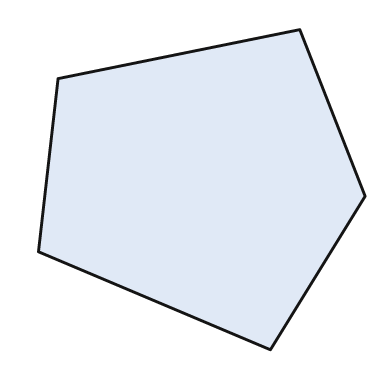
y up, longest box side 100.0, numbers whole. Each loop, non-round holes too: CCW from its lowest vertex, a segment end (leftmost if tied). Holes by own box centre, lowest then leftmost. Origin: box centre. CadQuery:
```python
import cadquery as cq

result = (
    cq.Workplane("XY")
    .moveTo(21.0, -49.0)
    .lineTo(50.0, -2.0)
    .lineTo(30.0, 49.0)
    .lineTo(-44.0, 34.0)
    .lineTo(-50.0, -19.0)
    .close()
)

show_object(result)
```